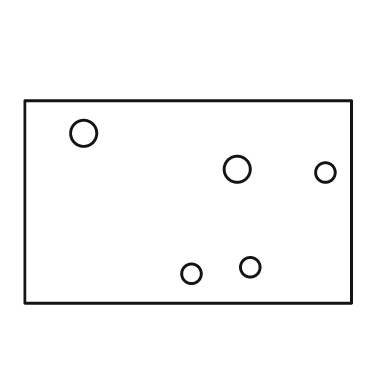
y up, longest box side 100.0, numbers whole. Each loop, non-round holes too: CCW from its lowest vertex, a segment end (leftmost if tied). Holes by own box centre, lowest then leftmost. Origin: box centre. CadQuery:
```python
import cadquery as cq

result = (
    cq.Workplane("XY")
    .moveTo(-50.0, -31.0)
    .lineTo(50.0, -31.0)
    .lineTo(50.0, 31.0)
    .lineTo(-50.0, 31.0)
    .close()
    .moveTo(1.0, -22.0)
    .circle(3.0)
    .moveTo(19.0, -20.0)
    .circle(3.0)
    .moveTo(42.0, 9.0)
    .circle(3.0)
    .moveTo(15.0, 10.0)
    .circle(4.0)
    .moveTo(-32.0, 21.0)
    .circle(4.0)
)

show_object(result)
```